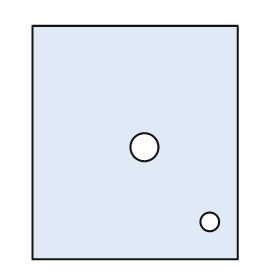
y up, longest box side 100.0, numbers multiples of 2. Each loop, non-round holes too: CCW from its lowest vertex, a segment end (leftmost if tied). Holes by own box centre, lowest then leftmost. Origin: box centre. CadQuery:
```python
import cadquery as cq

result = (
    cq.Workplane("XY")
    .moveTo(-44.0, -50.0)
    .lineTo(44.0, -50.0)
    .lineTo(44.0, 50.0)
    .lineTo(-44.0, 50.0)
    .close()
    .moveTo(32.0, -34.0)
    .circle(4.0)
    .moveTo(4.0, -2.0)
    .circle(6.0)
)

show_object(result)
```